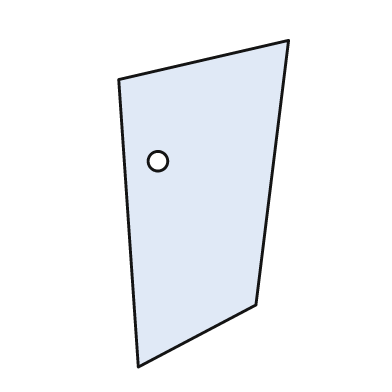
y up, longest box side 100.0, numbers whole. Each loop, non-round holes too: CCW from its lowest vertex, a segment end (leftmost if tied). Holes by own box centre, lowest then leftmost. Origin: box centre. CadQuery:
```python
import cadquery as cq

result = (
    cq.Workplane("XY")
    .moveTo(-20.0, -50.0)
    .lineTo(16.0, -31.0)
    .lineTo(26.0, 50.0)
    .lineTo(-26.0, 38.0)
    .close()
    .moveTo(-14.0, 13.0)
    .circle(3.0)
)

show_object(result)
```